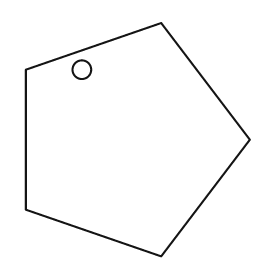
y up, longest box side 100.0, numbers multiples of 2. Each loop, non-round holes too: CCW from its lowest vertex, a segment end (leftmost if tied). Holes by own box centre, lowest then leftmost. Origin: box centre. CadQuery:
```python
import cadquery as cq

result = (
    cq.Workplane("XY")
    .moveTo(10.0, -50.0)
    .lineTo(48.0, 0.0)
    .lineTo(10.0, 50.0)
    .lineTo(-48.0, 30.0)
    .lineTo(-48.0, -30.0)
    .close()
    .moveTo(-24.0, 30.0)
    .circle(4.0)
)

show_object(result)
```